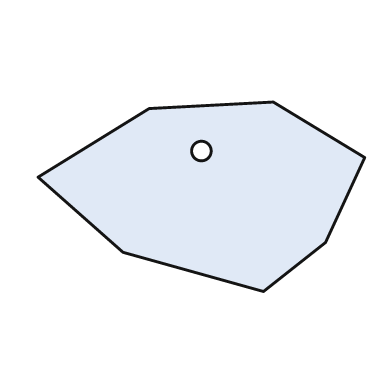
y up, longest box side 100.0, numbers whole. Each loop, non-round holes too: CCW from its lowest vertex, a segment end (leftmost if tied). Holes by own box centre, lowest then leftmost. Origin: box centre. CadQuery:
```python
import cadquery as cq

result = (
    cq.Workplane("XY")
    .moveTo(19.0, -29.0)
    .lineTo(38.0, -14.0)
    .lineTo(50.0, 12.0)
    .lineTo(22.0, 29.0)
    .lineTo(-16.0, 27.0)
    .lineTo(-50.0, 6.0)
    .lineTo(-24.0, -17.0)
    .close()
    .moveTo(0.0, 14.0)
    .circle(3.0)
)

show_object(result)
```